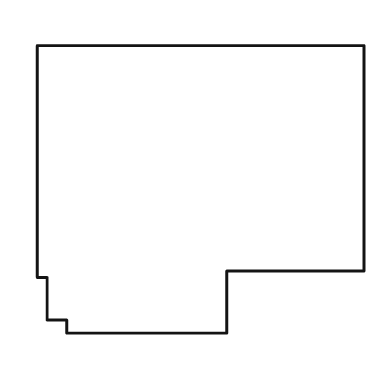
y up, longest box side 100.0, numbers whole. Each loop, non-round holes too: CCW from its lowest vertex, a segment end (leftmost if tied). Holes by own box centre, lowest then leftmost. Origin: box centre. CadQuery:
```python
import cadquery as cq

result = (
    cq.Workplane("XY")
    .moveTo(-41.0, -44.0)
    .lineTo(8.0, -44.0)
    .lineTo(8.0, -25.0)
    .lineTo(50.0, -25.0)
    .lineTo(50.0, 44.0)
    .lineTo(-50.0, 44.0)
    .lineTo(-50.0, -27.0)
    .lineTo(-47.0, -27.0)
    .lineTo(-47.0, -40.0)
    .lineTo(-41.0, -40.0)
    .close()
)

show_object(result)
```